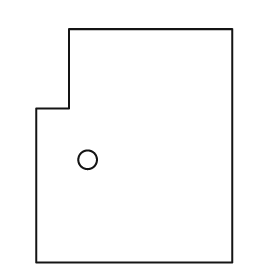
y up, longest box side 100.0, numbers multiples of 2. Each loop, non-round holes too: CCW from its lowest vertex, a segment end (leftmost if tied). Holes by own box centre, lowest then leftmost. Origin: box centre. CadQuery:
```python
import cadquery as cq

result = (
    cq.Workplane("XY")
    .moveTo(-42.0, -50.0)
    .lineTo(42.0, -50.0)
    .lineTo(42.0, 50.0)
    .lineTo(-28.0, 50.0)
    .lineTo(-28.0, 16.0)
    .lineTo(-42.0, 16.0)
    .close()
    .moveTo(-20.0, -6.0)
    .circle(4.0)
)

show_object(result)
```